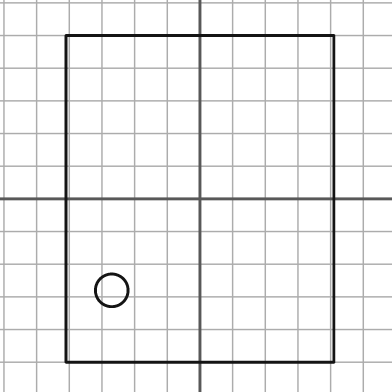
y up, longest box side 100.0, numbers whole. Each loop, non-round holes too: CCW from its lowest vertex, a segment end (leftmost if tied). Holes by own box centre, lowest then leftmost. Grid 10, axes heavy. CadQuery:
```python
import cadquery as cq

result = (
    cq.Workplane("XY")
    .moveTo(-41.0, -50.0)
    .lineTo(41.0, -50.0)
    .lineTo(41.0, 50.0)
    .lineTo(-41.0, 50.0)
    .close()
    .moveTo(-27.0, -28.0)
    .circle(5.0)
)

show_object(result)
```